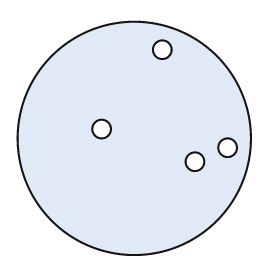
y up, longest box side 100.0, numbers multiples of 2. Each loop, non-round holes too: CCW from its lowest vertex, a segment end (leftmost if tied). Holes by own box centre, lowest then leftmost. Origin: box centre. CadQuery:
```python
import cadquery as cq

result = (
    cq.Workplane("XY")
    .moveTo(0.0, 0.0)
    .circle(50.0)
    .moveTo(26.0, -10.0)
    .circle(4.0)
    .moveTo(40.0, -4.0)
    .circle(4.0)
    .moveTo(-14.0, 4.0)
    .circle(4.0)
    .moveTo(12.0, 38.0)
    .circle(4.0)
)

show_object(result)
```